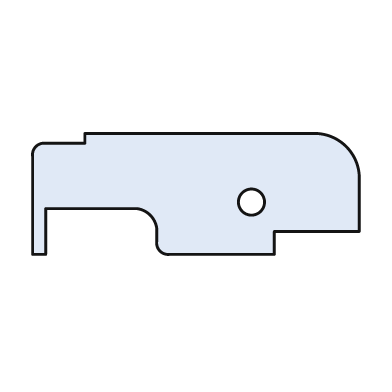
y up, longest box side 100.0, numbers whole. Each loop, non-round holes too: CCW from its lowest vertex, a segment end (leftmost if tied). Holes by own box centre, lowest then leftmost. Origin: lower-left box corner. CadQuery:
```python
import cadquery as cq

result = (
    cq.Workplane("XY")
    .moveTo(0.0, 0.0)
    .lineTo(4.0, 0.0)
    .lineTo(4.0, 14.0)
    .lineTo(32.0, 14.0)
    .threePointArc((36.0, 12.0), (38.0, 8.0))
    .lineTo(38.0, 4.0)
    .threePointArc((39.0, 1.0), (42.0, 0.0))
    .lineTo(74.0, 0.0)
    .lineTo(74.0, 7.0)
    .lineTo(100.0, 7.0)
    .lineTo(100.0, 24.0)
    .threePointArc((96.0, 33.0), (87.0, 37.0))
    .lineTo(16.0, 37.0)
    .lineTo(16.0, 34.0)
    .lineTo(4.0, 34.0)
    .threePointArc((1.0, 33.0), (0.0, 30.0))
    .close()
    .moveTo(67.0, 16.0)
    .circle(4.0)
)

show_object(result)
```